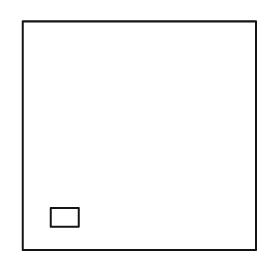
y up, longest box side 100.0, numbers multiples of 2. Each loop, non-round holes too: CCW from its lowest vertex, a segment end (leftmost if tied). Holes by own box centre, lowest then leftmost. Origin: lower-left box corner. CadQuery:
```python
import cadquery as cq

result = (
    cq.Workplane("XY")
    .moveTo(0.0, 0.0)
    .lineTo(100.0, 0.0)
    .lineTo(100.0, 98.0)
    .lineTo(0.0, 98.0)
    .close()
    .moveTo(12.0, 10.0)
    .lineTo(24.0, 10.0)
    .lineTo(24.0, 18.0)
    .lineTo(12.0, 18.0)
    .close()
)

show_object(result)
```